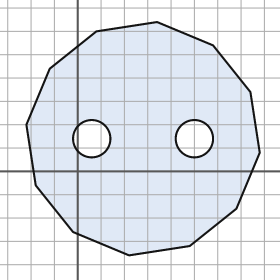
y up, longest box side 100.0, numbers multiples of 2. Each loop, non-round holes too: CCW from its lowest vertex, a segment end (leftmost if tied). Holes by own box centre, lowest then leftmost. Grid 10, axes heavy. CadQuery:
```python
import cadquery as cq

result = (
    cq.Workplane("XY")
    .moveTo(22.0, -36.0)
    .lineTo(48.0, -32.0)
    .lineTo(68.0, -16.0)
    .lineTo(78.0, 8.0)
    .lineTo(74.0, 34.0)
    .lineTo(58.0, 54.0)
    .lineTo(34.0, 64.0)
    .lineTo(8.0, 60.0)
    .lineTo(-12.0, 44.0)
    .lineTo(-22.0, 20.0)
    .lineTo(-18.0, -6.0)
    .lineTo(-2.0, -26.0)
    .close()
    .moveTo(6.0, 14.0)
    .circle(8.0)
    .moveTo(50.0, 14.0)
    .circle(8.0)
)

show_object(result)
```